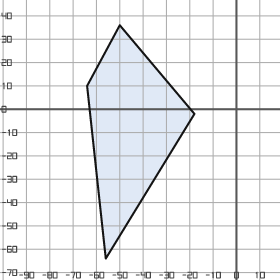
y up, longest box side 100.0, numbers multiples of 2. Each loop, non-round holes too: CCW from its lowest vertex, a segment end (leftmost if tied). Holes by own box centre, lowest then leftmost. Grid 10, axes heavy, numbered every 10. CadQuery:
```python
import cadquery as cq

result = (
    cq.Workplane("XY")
    .moveTo(-56.0, -64.0)
    .lineTo(-18.0, -2.0)
    .lineTo(-50.0, 36.0)
    .lineTo(-64.0, 10.0)
    .close()
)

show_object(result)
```